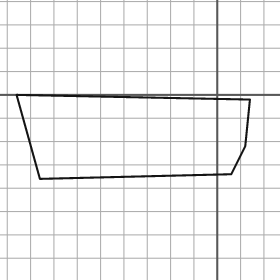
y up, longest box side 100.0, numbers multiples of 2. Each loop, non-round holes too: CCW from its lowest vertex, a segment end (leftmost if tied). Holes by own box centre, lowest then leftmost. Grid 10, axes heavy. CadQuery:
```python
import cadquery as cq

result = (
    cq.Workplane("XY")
    .moveTo(-76.0, -36.0)
    .lineTo(6.0, -34.0)
    .lineTo(12.0, -22.0)
    .lineTo(14.0, -2.0)
    .lineTo(-86.0, 0.0)
    .close()
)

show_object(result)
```